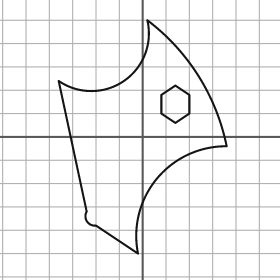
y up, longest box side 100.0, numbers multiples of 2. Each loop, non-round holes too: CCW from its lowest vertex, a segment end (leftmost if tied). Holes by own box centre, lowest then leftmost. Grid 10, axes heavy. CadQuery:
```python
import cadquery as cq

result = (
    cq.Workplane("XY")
    .moveTo(-2.0, -50.0)
    .threePointArc((6.0, -18.0), (36.0, -4.0))
    .threePointArc((24.0, 26.0), (2.0, 50.0))
    .threePointArc((-8.0, 24.0), (-36.0, 24.0))
    .lineTo(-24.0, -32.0)
    .threePointArc((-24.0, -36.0), (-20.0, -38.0))
    .close()
    .moveTo(14.0, 6.0)
    .lineTo(20.0, 10.0)
    .lineTo(20.0, 18.0)
    .lineTo(14.0, 22.0)
    .lineTo(8.0, 18.0)
    .lineTo(8.0, 10.0)
    .close()
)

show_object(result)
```